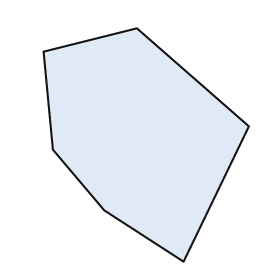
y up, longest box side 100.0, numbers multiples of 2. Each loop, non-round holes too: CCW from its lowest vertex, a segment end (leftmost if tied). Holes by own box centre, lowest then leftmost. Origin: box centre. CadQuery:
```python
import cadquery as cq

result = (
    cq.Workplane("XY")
    .moveTo(16.0, -50.0)
    .lineTo(44.0, 8.0)
    .lineTo(-4.0, 50.0)
    .lineTo(-44.0, 40.0)
    .lineTo(-40.0, -2.0)
    .lineTo(-18.0, -28.0)
    .close()
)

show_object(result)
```